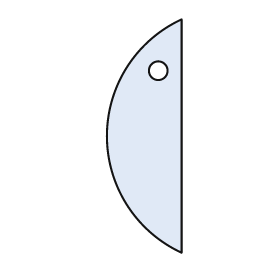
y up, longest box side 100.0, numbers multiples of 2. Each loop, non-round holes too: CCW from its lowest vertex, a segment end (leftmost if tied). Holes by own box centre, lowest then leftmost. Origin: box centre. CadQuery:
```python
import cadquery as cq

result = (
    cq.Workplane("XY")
    .moveTo(16.0, -50.0)
    .lineTo(16.0, 50.0)
    .threePointArc((-16.0, 0.0), (16.0, -50.0))
    .close()
    .moveTo(6.0, 28.0)
    .circle(4.0)
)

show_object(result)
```